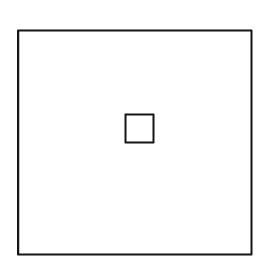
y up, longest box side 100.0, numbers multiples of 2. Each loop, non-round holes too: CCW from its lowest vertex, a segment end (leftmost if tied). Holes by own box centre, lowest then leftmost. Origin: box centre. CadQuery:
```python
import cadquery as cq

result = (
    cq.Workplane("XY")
    .moveTo(-50.0, -48.0)
    .lineTo(50.0, -48.0)
    .lineTo(50.0, 48.0)
    .lineTo(-50.0, 48.0)
    .close()
    .moveTo(-4.0, 0.0)
    .lineTo(8.0, 0.0)
    .lineTo(8.0, 12.0)
    .lineTo(-4.0, 12.0)
    .close()
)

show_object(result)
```